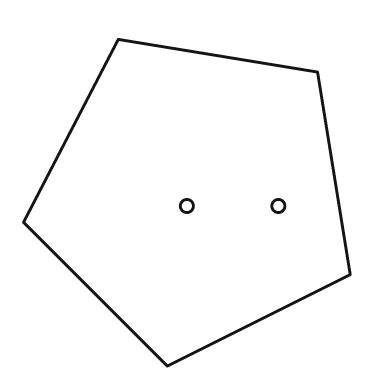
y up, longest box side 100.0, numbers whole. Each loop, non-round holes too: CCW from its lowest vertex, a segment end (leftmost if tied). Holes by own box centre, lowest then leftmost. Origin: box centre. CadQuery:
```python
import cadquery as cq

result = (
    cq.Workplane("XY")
    .moveTo(-6.0, -50.0)
    .lineTo(50.0, -22.0)
    .lineTo(40.0, 40.0)
    .lineTo(-21.0, 50.0)
    .lineTo(-50.0, -6.0)
    .close()
    .moveTo(0.0, -1.0)
    .circle(2.0)
    .moveTo(28.0, -1.0)
    .circle(2.0)
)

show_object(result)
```